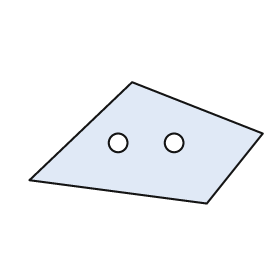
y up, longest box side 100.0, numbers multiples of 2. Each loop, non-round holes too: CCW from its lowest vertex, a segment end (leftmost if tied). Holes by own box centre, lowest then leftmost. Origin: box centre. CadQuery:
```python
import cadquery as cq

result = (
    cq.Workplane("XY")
    .moveTo(26.0, -26.0)
    .lineTo(50.0, 4.0)
    .lineTo(-6.0, 26.0)
    .lineTo(-50.0, -16.0)
    .close()
    .moveTo(-12.0, 0.0)
    .circle(4.0)
    .moveTo(12.0, 0.0)
    .circle(4.0)
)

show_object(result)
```